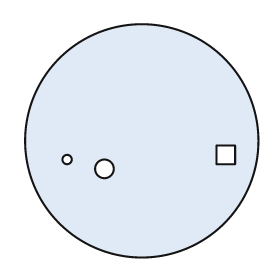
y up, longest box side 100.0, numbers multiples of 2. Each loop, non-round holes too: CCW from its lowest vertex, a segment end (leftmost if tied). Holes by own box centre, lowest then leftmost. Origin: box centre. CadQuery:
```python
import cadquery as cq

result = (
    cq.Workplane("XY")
    .moveTo(0.0, 0.0)
    .circle(50.0)
    .moveTo(-16.0, -12.0)
    .circle(4.0)
    .moveTo(-32.0, -8.0)
    .circle(2.0)
    .moveTo(32.0, -10.0)
    .lineTo(40.0, -10.0)
    .lineTo(40.0, -2.0)
    .lineTo(32.0, -2.0)
    .close()
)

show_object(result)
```